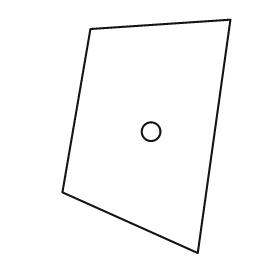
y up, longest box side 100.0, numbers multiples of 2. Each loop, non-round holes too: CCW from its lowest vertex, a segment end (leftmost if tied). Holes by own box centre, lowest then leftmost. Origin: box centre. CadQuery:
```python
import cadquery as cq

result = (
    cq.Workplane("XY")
    .moveTo(22.0, -50.0)
    .lineTo(36.0, 50.0)
    .lineTo(-24.0, 46.0)
    .lineTo(-36.0, -24.0)
    .close()
    .moveTo(2.0, 2.0)
    .circle(4.0)
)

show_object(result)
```